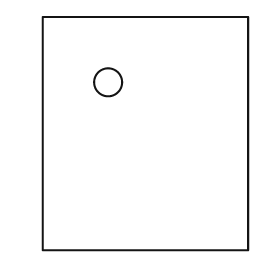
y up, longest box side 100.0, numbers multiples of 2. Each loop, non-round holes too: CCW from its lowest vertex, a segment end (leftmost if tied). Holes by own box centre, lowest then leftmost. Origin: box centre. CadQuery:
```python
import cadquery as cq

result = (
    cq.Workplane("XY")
    .moveTo(-44.0, -50.0)
    .lineTo(44.0, -50.0)
    .lineTo(44.0, 50.0)
    .lineTo(-44.0, 50.0)
    .close()
    .moveTo(-16.0, 22.0)
    .circle(6.0)
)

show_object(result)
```